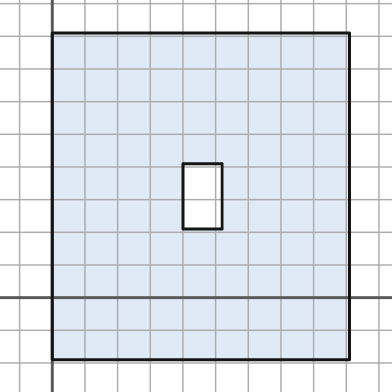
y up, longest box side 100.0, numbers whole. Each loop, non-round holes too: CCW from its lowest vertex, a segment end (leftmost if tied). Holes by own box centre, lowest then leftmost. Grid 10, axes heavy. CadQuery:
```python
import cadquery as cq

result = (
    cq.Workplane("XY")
    .moveTo(0.0, -19.0)
    .lineTo(91.0, -19.0)
    .lineTo(91.0, 81.0)
    .lineTo(0.0, 81.0)
    .close()
    .moveTo(40.0, 21.0)
    .lineTo(52.0, 21.0)
    .lineTo(52.0, 41.0)
    .lineTo(40.0, 41.0)
    .close()
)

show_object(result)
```